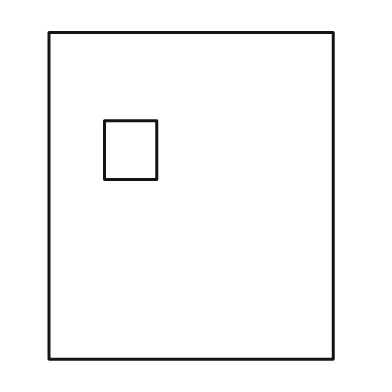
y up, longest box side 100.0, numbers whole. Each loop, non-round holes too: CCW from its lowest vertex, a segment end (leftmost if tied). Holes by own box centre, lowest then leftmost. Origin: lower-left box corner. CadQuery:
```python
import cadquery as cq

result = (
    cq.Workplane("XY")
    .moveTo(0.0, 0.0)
    .lineTo(87.0, 0.0)
    .lineTo(87.0, 100.0)
    .lineTo(0.0, 100.0)
    .close()
    .moveTo(17.0, 55.0)
    .lineTo(33.0, 55.0)
    .lineTo(33.0, 73.0)
    .lineTo(17.0, 73.0)
    .close()
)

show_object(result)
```